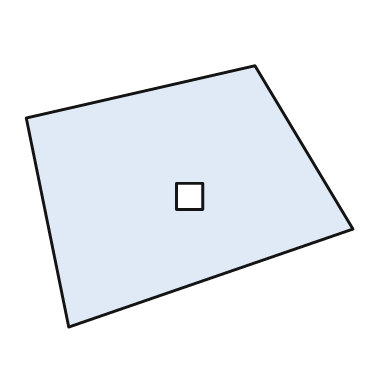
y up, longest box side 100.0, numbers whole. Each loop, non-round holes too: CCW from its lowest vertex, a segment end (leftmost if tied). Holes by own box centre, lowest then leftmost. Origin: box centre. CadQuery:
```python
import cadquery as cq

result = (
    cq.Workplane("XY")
    .moveTo(-37.0, -40.0)
    .lineTo(50.0, -10.0)
    .lineTo(20.0, 40.0)
    .lineTo(-50.0, 24.0)
    .close()
    .moveTo(-4.0, -4.0)
    .lineTo(4.0, -4.0)
    .lineTo(4.0, 4.0)
    .lineTo(-4.0, 4.0)
    .close()
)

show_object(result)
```